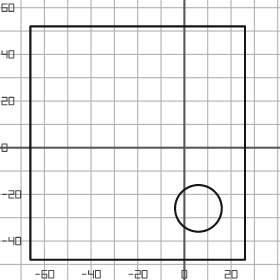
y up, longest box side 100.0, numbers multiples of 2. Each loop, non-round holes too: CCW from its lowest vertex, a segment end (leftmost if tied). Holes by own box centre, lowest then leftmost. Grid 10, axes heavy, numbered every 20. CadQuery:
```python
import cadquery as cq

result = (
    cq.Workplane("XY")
    .moveTo(-66.0, -48.0)
    .lineTo(26.0, -48.0)
    .lineTo(26.0, 52.0)
    .lineTo(-66.0, 52.0)
    .close()
    .moveTo(6.0, -26.0)
    .circle(10.0)
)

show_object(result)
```